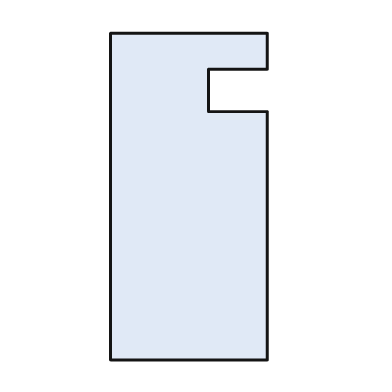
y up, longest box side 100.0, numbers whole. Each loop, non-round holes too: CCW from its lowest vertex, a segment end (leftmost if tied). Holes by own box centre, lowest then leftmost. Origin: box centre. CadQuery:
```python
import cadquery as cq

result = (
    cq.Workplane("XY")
    .moveTo(-24.0, -50.0)
    .lineTo(24.0, -50.0)
    .lineTo(24.0, 26.0)
    .lineTo(6.0, 26.0)
    .lineTo(6.0, 39.0)
    .lineTo(24.0, 39.0)
    .lineTo(24.0, 50.0)
    .lineTo(-24.0, 50.0)
    .close()
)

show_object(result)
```